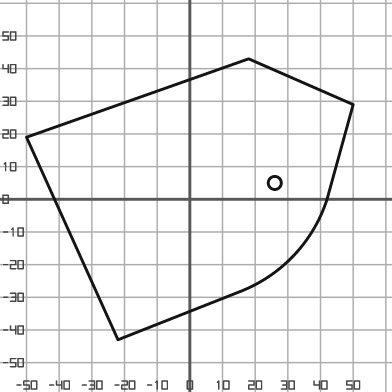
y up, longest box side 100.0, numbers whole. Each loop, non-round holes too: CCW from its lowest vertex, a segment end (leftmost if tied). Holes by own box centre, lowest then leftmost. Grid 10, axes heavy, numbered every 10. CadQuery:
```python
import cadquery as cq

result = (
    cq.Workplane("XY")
    .moveTo(-22.0, -43.0)
    .lineTo(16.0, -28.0)
    .threePointArc((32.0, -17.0), (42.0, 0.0))
    .lineTo(50.0, 29.0)
    .lineTo(18.0, 43.0)
    .lineTo(-50.0, 19.0)
    .close()
    .moveTo(26.0, 5.0)
    .circle(2.0)
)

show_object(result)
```